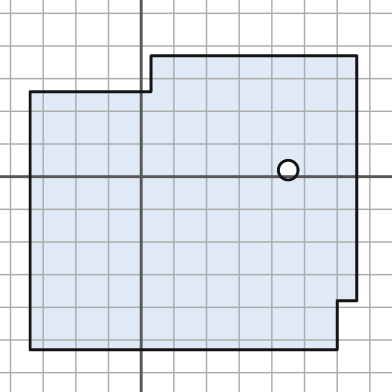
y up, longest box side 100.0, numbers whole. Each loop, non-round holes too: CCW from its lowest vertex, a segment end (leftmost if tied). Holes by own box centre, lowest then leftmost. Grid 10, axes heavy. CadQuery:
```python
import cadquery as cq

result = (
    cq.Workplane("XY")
    .moveTo(-34.0, -53.0)
    .lineTo(60.0, -53.0)
    .lineTo(60.0, -38.0)
    .lineTo(66.0, -38.0)
    .lineTo(66.0, 37.0)
    .lineTo(3.0, 37.0)
    .lineTo(3.0, 26.0)
    .lineTo(-34.0, 26.0)
    .close()
    .moveTo(45.0, 2.0)
    .circle(3.0)
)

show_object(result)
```